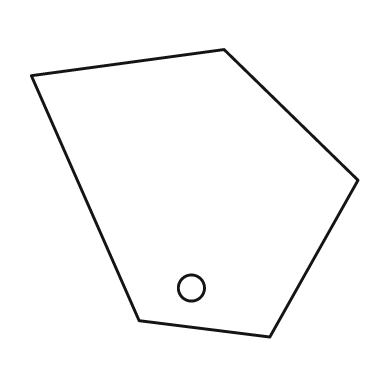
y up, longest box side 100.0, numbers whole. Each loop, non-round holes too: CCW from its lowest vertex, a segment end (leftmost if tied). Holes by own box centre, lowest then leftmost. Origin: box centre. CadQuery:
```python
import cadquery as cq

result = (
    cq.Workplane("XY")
    .moveTo(23.0, -44.0)
    .lineTo(50.0, 4.0)
    .lineTo(9.0, 44.0)
    .lineTo(-50.0, 36.0)
    .lineTo(-17.0, -39.0)
    .close()
    .moveTo(-1.0, -29.0)
    .circle(4.0)
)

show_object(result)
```